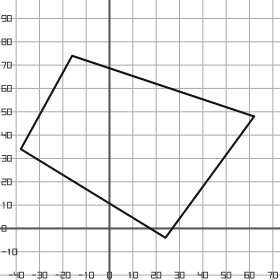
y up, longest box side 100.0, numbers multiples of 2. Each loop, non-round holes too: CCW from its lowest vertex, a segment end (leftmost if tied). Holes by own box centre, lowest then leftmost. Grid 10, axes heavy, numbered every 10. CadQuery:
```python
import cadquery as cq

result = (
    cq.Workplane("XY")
    .moveTo(24.0, -4.0)
    .lineTo(62.0, 48.0)
    .lineTo(-16.0, 74.0)
    .lineTo(-38.0, 34.0)
    .close()
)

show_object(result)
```